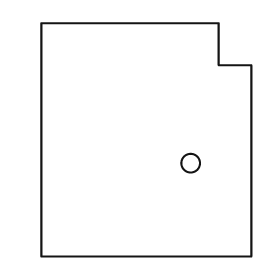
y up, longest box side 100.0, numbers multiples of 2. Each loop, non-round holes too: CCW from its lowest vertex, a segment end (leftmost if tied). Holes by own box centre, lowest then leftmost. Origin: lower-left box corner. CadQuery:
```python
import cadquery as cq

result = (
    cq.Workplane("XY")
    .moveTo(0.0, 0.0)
    .lineTo(90.0, 0.0)
    .lineTo(90.0, 82.0)
    .lineTo(76.0, 82.0)
    .lineTo(76.0, 100.0)
    .lineTo(0.0, 100.0)
    .close()
    .moveTo(64.0, 40.0)
    .circle(4.0)
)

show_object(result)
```